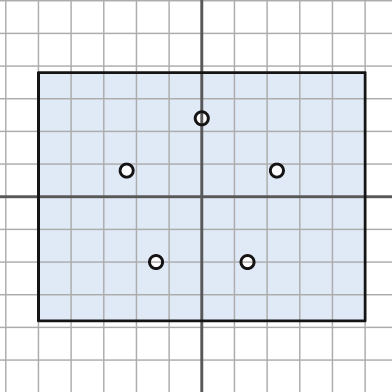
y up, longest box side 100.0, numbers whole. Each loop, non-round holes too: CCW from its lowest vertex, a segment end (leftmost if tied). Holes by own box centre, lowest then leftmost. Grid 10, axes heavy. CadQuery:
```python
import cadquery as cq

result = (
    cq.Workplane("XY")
    .moveTo(-50.0, -38.0)
    .lineTo(50.0, -38.0)
    .lineTo(50.0, 38.0)
    .lineTo(-50.0, 38.0)
    .close()
    .moveTo(-14.0, -20.0)
    .circle(2.0)
    .moveTo(14.0, -20.0)
    .circle(2.0)
    .moveTo(-23.0, 8.0)
    .circle(2.0)
    .moveTo(23.0, 8.0)
    .circle(2.0)
    .moveTo(0.0, 24.0)
    .circle(2.0)
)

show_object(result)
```